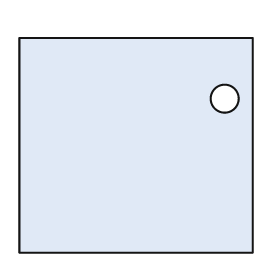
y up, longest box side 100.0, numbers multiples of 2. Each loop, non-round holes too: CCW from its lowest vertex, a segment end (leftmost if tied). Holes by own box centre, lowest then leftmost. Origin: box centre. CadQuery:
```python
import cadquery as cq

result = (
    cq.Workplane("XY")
    .moveTo(-50.0, -46.0)
    .lineTo(50.0, -46.0)
    .lineTo(50.0, 46.0)
    .lineTo(-50.0, 46.0)
    .close()
    .moveTo(38.0, 20.0)
    .circle(6.0)
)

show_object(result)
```